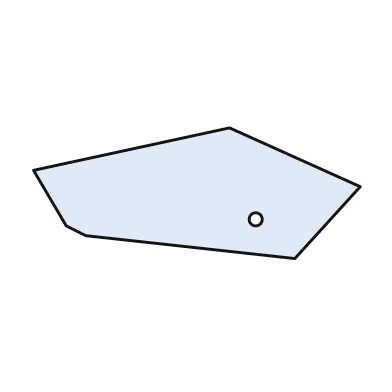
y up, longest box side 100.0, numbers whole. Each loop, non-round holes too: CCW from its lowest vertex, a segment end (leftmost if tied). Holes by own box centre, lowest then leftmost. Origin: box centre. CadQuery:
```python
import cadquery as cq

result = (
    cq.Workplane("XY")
    .moveTo(30.0, -20.0)
    .lineTo(50.0, 2.0)
    .lineTo(10.0, 20.0)
    .lineTo(-50.0, 7.0)
    .lineTo(-40.0, -10.0)
    .lineTo(-34.0, -13.0)
    .close()
    .moveTo(18.0, -8.0)
    .circle(2.0)
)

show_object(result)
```